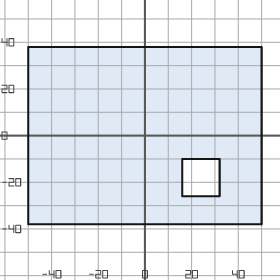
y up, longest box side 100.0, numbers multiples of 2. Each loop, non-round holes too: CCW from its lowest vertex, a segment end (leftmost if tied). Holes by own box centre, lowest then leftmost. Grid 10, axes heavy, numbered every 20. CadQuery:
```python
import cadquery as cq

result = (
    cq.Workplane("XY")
    .moveTo(-50.0, -38.0)
    .lineTo(50.0, -38.0)
    .lineTo(50.0, 38.0)
    .lineTo(-50.0, 38.0)
    .close()
    .moveTo(16.0, -26.0)
    .lineTo(32.0, -26.0)
    .lineTo(32.0, -10.0)
    .lineTo(16.0, -10.0)
    .close()
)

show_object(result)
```